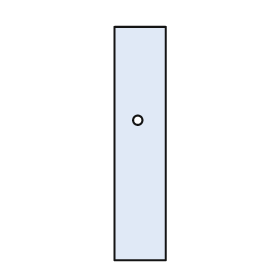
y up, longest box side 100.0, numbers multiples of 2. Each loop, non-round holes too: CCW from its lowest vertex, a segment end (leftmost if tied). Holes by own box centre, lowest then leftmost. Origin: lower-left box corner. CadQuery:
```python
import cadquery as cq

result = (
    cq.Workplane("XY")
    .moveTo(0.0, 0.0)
    .lineTo(22.0, 0.0)
    .lineTo(22.0, 100.0)
    .lineTo(0.0, 100.0)
    .close()
    .moveTo(10.0, 60.0)
    .circle(2.0)
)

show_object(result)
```